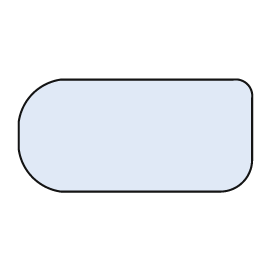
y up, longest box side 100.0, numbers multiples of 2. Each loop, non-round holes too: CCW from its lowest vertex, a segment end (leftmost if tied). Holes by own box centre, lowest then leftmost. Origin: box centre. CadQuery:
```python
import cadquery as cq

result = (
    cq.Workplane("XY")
    .moveTo(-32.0, -24.0)
    .lineTo(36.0, -24.0)
    .threePointArc((46.0, -20.0), (50.0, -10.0))
    .lineTo(50.0, 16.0)
    .threePointArc((48.0, 22.0), (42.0, 24.0))
    .lineTo(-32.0, 24.0)
    .threePointArc((-44.0, 18.0), (-50.0, 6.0))
    .lineTo(-50.0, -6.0)
    .threePointArc((-44.0, -18.0), (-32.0, -24.0))
    .close()
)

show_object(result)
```